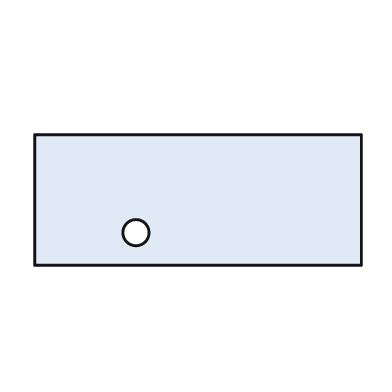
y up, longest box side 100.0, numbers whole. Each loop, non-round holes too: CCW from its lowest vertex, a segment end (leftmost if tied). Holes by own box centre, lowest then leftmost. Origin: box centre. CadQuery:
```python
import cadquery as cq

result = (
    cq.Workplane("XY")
    .moveTo(-50.0, -20.0)
    .lineTo(50.0, -20.0)
    .lineTo(50.0, 20.0)
    .lineTo(-50.0, 20.0)
    .close()
    .moveTo(-19.0, -10.0)
    .circle(4.0)
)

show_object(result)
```